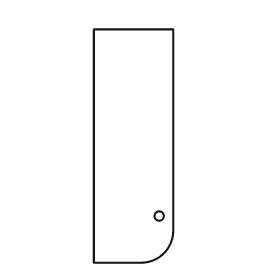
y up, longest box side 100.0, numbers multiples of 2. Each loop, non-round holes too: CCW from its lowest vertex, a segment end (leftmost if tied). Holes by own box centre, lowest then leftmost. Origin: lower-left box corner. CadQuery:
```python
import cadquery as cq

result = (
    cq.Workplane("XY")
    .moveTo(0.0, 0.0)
    .lineTo(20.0, 0.0)
    .threePointArc((30.0, 4.0), (34.0, 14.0))
    .lineTo(34.0, 100.0)
    .lineTo(0.0, 100.0)
    .close()
    .moveTo(28.0, 20.0)
    .circle(2.0)
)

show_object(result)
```